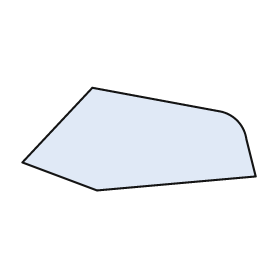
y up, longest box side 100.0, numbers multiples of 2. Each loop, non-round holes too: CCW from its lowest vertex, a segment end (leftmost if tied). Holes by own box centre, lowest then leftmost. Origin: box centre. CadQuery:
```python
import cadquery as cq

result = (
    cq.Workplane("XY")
    .moveTo(-18.0, -22.0)
    .lineTo(50.0, -16.0)
    .lineTo(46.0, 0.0)
    .threePointArc((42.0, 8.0), (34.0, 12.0))
    .lineTo(-20.0, 22.0)
    .lineTo(-50.0, -10.0)
    .close()
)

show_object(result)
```